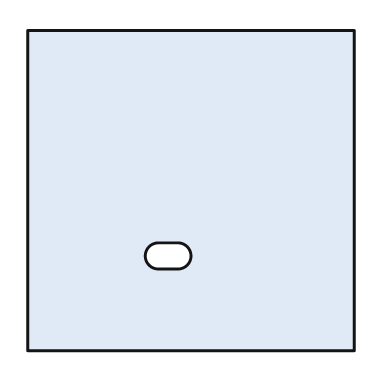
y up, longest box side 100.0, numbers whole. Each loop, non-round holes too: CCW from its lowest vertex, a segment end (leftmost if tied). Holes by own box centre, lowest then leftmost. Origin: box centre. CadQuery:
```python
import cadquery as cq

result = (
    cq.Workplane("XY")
    .moveTo(-50.0, -49.0)
    .lineTo(50.0, -49.0)
    .lineTo(50.0, 49.0)
    .lineTo(-50.0, 49.0)
    .close()
    .moveTo(-10.0, -24.0)
    .lineTo(-4.0, -24.0)
    .threePointArc((0.0, -20.0), (-4.0, -16.0))
    .lineTo(-10.0, -16.0)
    .threePointArc((-14.0, -20.0), (-10.0, -24.0))
    .close()
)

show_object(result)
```